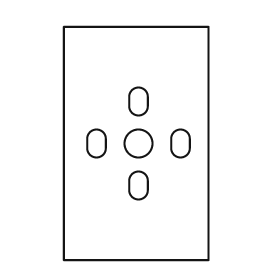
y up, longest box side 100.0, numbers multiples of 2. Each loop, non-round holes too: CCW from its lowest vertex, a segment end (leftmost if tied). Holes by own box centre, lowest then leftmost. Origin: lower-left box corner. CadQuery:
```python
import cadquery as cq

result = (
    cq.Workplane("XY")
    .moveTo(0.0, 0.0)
    .lineTo(62.0, 0.0)
    .lineTo(62.0, 100.0)
    .lineTo(0.0, 100.0)
    .close()
    .moveTo(28.0, 30.0)
    .threePointArc((32.0, 26.0), (36.0, 30.0))
    .lineTo(36.0, 34.0)
    .threePointArc((32.0, 38.0), (28.0, 34.0))
    .close()
    .moveTo(10.0, 48.0)
    .threePointArc((14.0, 44.0), (18.0, 48.0))
    .lineTo(18.0, 52.0)
    .threePointArc((14.0, 56.0), (10.0, 52.0))
    .close()
    .moveTo(32.0, 50.0)
    .circle(6.0)
    .moveTo(46.0, 48.0)
    .threePointArc((50.0, 44.0), (54.0, 48.0))
    .lineTo(54.0, 52.0)
    .threePointArc((50.0, 56.0), (46.0, 52.0))
    .close()
    .moveTo(28.0, 66.0)
    .threePointArc((32.0, 62.0), (36.0, 66.0))
    .lineTo(36.0, 70.0)
    .threePointArc((32.0, 74.0), (28.0, 70.0))
    .close()
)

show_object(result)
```